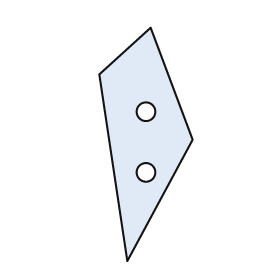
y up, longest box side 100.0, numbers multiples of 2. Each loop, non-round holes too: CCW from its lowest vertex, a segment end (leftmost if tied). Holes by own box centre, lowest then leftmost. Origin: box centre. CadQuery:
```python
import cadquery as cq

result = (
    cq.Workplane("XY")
    .moveTo(-8.0, -50.0)
    .lineTo(20.0, 2.0)
    .lineTo(2.0, 50.0)
    .lineTo(-20.0, 30.0)
    .close()
    .moveTo(0.0, -12.0)
    .circle(4.0)
    .moveTo(0.0, 14.0)
    .circle(4.0)
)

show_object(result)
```